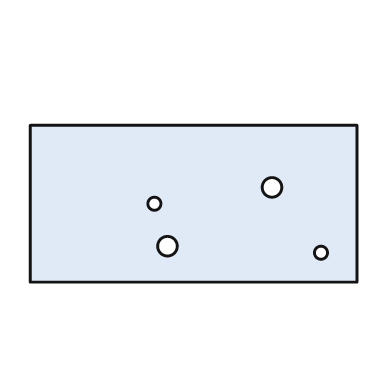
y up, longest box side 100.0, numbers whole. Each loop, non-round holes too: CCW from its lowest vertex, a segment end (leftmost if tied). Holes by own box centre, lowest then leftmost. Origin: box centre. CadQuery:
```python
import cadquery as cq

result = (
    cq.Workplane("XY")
    .moveTo(-50.0, -24.0)
    .lineTo(50.0, -24.0)
    .lineTo(50.0, 24.0)
    .lineTo(-50.0, 24.0)
    .close()
    .moveTo(39.0, -15.0)
    .circle(2.0)
    .moveTo(-8.0, -13.0)
    .circle(3.0)
    .moveTo(-12.0, 0.0)
    .circle(2.0)
    .moveTo(24.0, 5.0)
    .circle(3.0)
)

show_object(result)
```